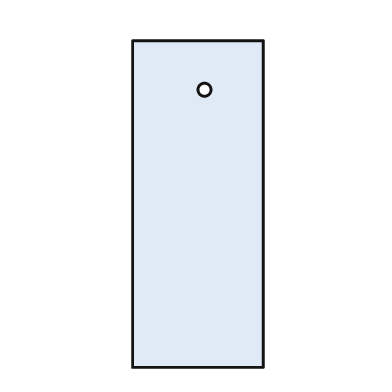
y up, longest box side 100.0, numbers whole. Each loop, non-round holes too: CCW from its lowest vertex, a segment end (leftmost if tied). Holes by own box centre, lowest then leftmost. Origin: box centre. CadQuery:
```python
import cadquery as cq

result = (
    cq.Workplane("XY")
    .moveTo(-20.0, -50.0)
    .lineTo(20.0, -50.0)
    .lineTo(20.0, 50.0)
    .lineTo(-20.0, 50.0)
    .close()
    .moveTo(2.0, 35.0)
    .circle(2.0)
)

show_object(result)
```